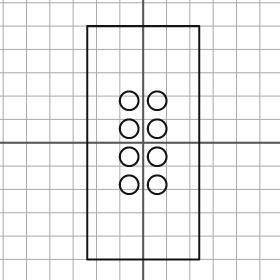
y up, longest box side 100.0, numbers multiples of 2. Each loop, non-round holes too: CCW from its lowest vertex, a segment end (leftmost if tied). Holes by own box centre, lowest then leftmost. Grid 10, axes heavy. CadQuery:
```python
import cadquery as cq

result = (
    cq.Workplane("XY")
    .moveTo(-24.0, -50.0)
    .lineTo(24.0, -50.0)
    .lineTo(24.0, 50.0)
    .lineTo(-24.0, 50.0)
    .close()
    .moveTo(-6.0, -18.0)
    .circle(4.0)
    .moveTo(6.0, -18.0)
    .circle(4.0)
    .moveTo(-6.0, -6.0)
    .circle(4.0)
    .moveTo(6.0, -6.0)
    .circle(4.0)
    .moveTo(-6.0, 6.0)
    .circle(4.0)
    .moveTo(6.0, 6.0)
    .circle(4.0)
    .moveTo(-6.0, 18.0)
    .circle(4.0)
    .moveTo(6.0, 18.0)
    .circle(4.0)
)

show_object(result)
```